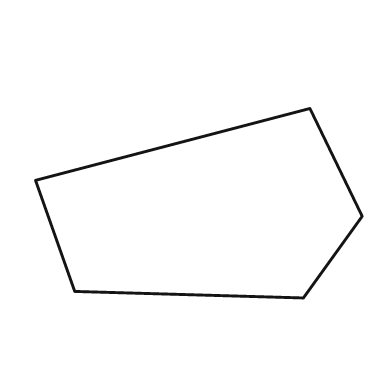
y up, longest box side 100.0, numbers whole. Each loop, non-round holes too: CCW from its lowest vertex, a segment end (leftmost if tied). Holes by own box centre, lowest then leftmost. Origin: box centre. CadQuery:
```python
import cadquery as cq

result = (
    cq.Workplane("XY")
    .moveTo(32.0, -29.0)
    .lineTo(50.0, -4.0)
    .lineTo(34.0, 29.0)
    .lineTo(-50.0, 7.0)
    .lineTo(-38.0, -27.0)
    .close()
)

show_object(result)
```